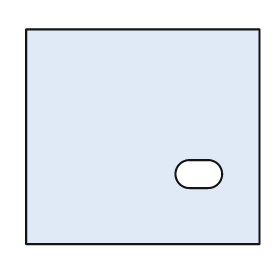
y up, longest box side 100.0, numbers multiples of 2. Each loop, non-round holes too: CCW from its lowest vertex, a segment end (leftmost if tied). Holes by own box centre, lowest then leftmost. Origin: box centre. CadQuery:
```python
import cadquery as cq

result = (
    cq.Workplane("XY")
    .moveTo(-50.0, -46.0)
    .lineTo(50.0, -46.0)
    .lineTo(50.0, 46.0)
    .lineTo(-50.0, 46.0)
    .close()
    .moveTo(20.0, -22.0)
    .lineTo(28.0, -22.0)
    .threePointArc((34.0, -16.0), (28.0, -10.0))
    .lineTo(20.0, -10.0)
    .threePointArc((14.0, -16.0), (20.0, -22.0))
    .close()
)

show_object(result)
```